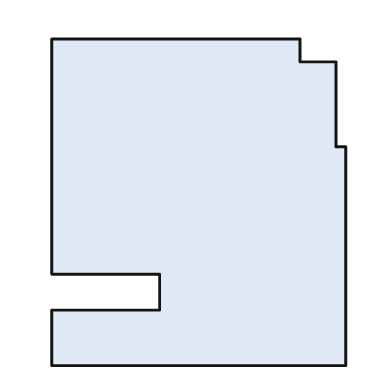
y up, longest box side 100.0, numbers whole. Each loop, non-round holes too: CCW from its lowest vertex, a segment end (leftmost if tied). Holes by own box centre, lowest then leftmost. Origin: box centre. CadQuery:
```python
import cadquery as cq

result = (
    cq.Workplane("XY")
    .moveTo(-45.0, -50.0)
    .lineTo(45.0, -50.0)
    .lineTo(45.0, 17.0)
    .lineTo(42.0, 17.0)
    .lineTo(42.0, 43.0)
    .lineTo(31.0, 43.0)
    .lineTo(31.0, 50.0)
    .lineTo(-45.0, 50.0)
    .lineTo(-45.0, -22.0)
    .lineTo(-12.0, -22.0)
    .lineTo(-12.0, -33.0)
    .lineTo(-45.0, -33.0)
    .close()
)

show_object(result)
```